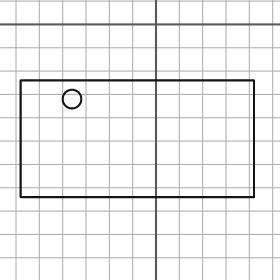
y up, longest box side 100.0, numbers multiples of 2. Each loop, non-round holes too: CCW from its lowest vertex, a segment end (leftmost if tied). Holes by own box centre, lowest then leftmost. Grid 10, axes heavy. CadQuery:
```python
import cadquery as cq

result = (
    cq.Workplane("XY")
    .moveTo(-58.0, -74.0)
    .lineTo(42.0, -74.0)
    .lineTo(42.0, -24.0)
    .lineTo(-58.0, -24.0)
    .close()
    .moveTo(-36.0, -32.0)
    .circle(4.0)
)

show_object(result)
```